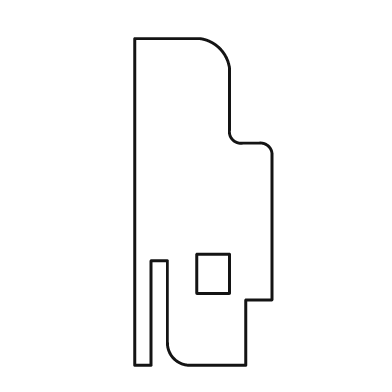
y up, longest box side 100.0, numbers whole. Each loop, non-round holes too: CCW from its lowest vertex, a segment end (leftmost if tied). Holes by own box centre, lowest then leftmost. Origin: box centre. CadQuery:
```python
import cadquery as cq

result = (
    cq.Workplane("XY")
    .moveTo(-21.0, -50.0)
    .lineTo(-16.0, -50.0)
    .lineTo(-16.0, -18.0)
    .lineTo(-11.0, -18.0)
    .lineTo(-11.0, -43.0)
    .threePointArc((-9.0, -48.0), (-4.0, -50.0))
    .lineTo(13.0, -50.0)
    .lineTo(13.0, -30.0)
    .lineTo(21.0, -30.0)
    .lineTo(21.0, 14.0)
    .threePointArc((20.0, 17.0), (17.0, 18.0))
    .lineTo(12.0, 18.0)
    .threePointArc((9.0, 19.0), (8.0, 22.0))
    .lineTo(8.0, 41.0)
    .threePointArc((5.0, 47.0), (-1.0, 50.0))
    .lineTo(-21.0, 50.0)
    .close()
    .moveTo(-2.0, -28.0)
    .lineTo(8.0, -28.0)
    .lineTo(8.0, -16.0)
    .lineTo(-2.0, -16.0)
    .close()
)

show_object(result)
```